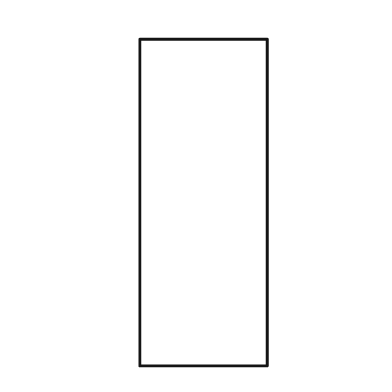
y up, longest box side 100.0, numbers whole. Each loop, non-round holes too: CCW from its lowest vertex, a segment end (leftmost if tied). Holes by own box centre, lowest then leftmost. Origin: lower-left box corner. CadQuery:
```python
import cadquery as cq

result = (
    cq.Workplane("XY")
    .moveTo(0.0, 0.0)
    .lineTo(39.0, 0.0)
    .lineTo(39.0, 100.0)
    .lineTo(0.0, 100.0)
    .close()
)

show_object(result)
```